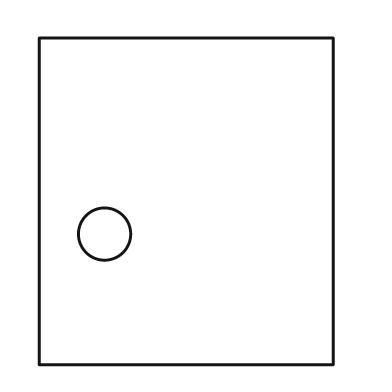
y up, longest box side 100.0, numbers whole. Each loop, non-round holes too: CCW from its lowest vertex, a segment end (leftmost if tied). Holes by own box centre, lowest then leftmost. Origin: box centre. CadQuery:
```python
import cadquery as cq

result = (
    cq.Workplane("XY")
    .moveTo(-45.0, -50.0)
    .lineTo(45.0, -50.0)
    .lineTo(45.0, 50.0)
    .lineTo(-45.0, 50.0)
    .close()
    .moveTo(-25.0, -10.0)
    .circle(8.0)
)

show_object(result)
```